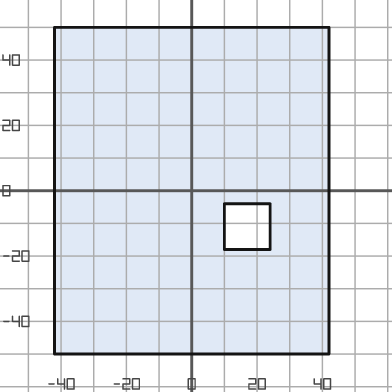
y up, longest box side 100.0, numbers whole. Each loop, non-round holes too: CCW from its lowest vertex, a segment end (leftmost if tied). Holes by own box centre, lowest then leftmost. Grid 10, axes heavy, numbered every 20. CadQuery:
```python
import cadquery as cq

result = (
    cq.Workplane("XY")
    .moveTo(-42.0, -50.0)
    .lineTo(42.0, -50.0)
    .lineTo(42.0, 50.0)
    .lineTo(-42.0, 50.0)
    .close()
    .moveTo(10.0, -18.0)
    .lineTo(24.0, -18.0)
    .lineTo(24.0, -4.0)
    .lineTo(10.0, -4.0)
    .close()
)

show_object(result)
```